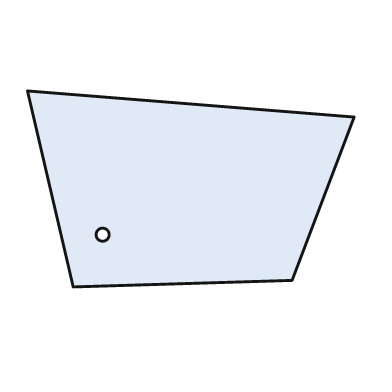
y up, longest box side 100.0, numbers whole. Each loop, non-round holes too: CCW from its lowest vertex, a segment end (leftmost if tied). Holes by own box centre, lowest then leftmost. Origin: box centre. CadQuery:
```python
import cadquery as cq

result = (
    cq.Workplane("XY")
    .moveTo(-36.0, -30.0)
    .lineTo(31.0, -28.0)
    .lineTo(50.0, 22.0)
    .lineTo(-50.0, 30.0)
    .close()
    .moveTo(-27.0, -14.0)
    .circle(2.0)
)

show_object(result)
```